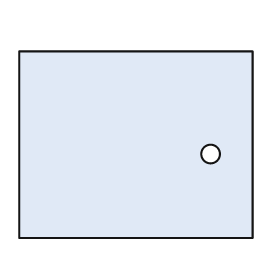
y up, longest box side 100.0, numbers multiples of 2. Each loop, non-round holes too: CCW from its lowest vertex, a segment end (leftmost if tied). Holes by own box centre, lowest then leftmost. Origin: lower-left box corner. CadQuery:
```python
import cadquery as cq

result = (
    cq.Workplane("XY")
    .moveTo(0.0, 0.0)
    .lineTo(100.0, 0.0)
    .lineTo(100.0, 80.0)
    .lineTo(0.0, 80.0)
    .close()
    .moveTo(82.0, 36.0)
    .circle(4.0)
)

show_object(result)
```